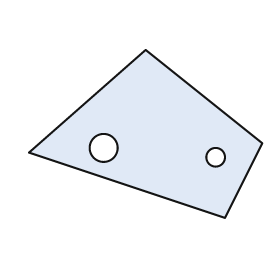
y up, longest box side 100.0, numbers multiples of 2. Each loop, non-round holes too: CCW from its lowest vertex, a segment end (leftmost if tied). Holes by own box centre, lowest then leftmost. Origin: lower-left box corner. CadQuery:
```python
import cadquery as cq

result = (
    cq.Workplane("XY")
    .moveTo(84.0, 0.0)
    .lineTo(100.0, 32.0)
    .lineTo(50.0, 72.0)
    .lineTo(0.0, 28.0)
    .close()
    .moveTo(80.0, 26.0)
    .circle(4.0)
    .moveTo(32.0, 30.0)
    .circle(6.0)
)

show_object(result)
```